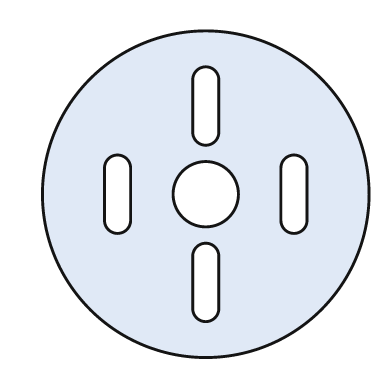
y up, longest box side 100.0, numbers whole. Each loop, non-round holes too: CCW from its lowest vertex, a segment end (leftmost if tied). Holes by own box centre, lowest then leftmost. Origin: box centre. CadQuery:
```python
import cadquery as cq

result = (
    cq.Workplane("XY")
    .moveTo(0.0, 0.0)
    .circle(50.0)
    .moveTo(-4.0, -35.0)
    .threePointArc((0.0, -39.0), (4.0, -35.0))
    .lineTo(4.0, -19.0)
    .threePointArc((0.0, -15.0), (-4.0, -19.0))
    .close()
    .moveTo(-31.0, -8.0)
    .threePointArc((-27.0, -12.0), (-23.0, -8.0))
    .lineTo(-23.0, 8.0)
    .threePointArc((-27.0, 12.0), (-31.0, 8.0))
    .close()
    .moveTo(0.0, 0.0)
    .circle(10.0)
    .moveTo(23.0, -8.0)
    .threePointArc((27.0, -12.0), (31.0, -8.0))
    .lineTo(31.0, 8.0)
    .threePointArc((27.0, 12.0), (23.0, 8.0))
    .close()
    .moveTo(-4.0, 19.0)
    .threePointArc((0.0, 15.0), (4.0, 19.0))
    .lineTo(4.0, 35.0)
    .threePointArc((0.0, 39.0), (-4.0, 35.0))
    .close()
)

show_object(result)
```